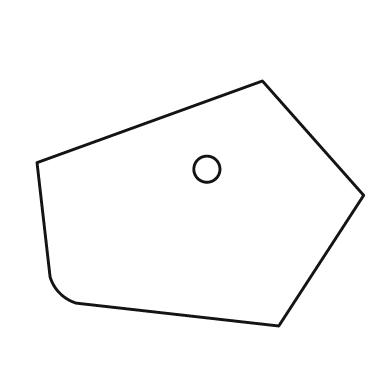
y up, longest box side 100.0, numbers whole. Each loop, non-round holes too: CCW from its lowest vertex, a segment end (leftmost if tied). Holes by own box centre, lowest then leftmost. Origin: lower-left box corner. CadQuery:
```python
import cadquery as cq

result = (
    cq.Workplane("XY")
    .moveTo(74.0, 0.0)
    .lineTo(100.0, 40.0)
    .lineTo(69.0, 75.0)
    .lineTo(0.0, 50.0)
    .lineTo(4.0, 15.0)
    .threePointArc((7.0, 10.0), (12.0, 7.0))
    .close()
    .moveTo(52.0, 48.0)
    .circle(4.0)
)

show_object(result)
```